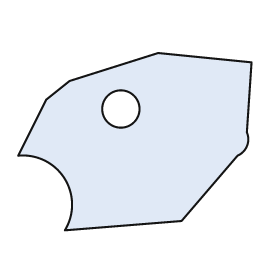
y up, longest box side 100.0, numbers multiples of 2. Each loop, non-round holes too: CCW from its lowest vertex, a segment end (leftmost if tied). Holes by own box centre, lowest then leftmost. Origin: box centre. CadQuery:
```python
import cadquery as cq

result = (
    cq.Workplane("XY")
    .moveTo(-30.0, -38.0)
    .lineTo(20.0, -34.0)
    .lineTo(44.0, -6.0)
    .threePointArc((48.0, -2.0), (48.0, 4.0))
    .lineTo(50.0, 34.0)
    .lineTo(10.0, 38.0)
    .lineTo(-28.0, 26.0)
    .lineTo(-38.0, 18.0)
    .lineTo(-50.0, -6.0)
    .threePointArc((-30.0, -16.0), (-30.0, -38.0))
    .close()
    .moveTo(-6.0, 14.0)
    .circle(8.0)
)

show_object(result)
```